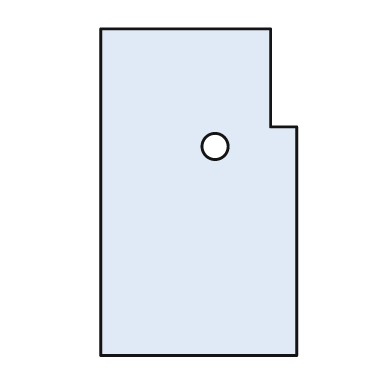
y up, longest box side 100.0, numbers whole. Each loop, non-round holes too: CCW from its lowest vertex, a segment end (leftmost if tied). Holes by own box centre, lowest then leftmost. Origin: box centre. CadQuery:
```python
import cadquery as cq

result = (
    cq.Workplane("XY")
    .moveTo(-30.0, -50.0)
    .lineTo(30.0, -50.0)
    .lineTo(30.0, 20.0)
    .lineTo(22.0, 20.0)
    .lineTo(22.0, 50.0)
    .lineTo(-30.0, 50.0)
    .close()
    .moveTo(5.0, 14.0)
    .circle(4.0)
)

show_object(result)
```